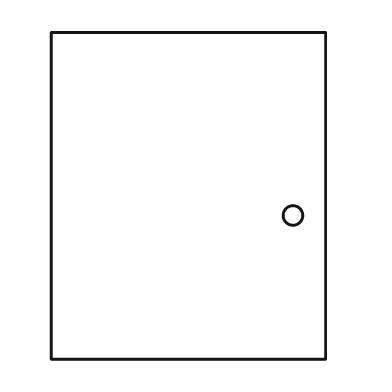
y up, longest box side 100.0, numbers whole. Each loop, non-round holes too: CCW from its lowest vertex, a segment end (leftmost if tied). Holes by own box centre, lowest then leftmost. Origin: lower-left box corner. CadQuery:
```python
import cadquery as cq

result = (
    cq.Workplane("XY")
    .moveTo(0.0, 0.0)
    .lineTo(84.0, 0.0)
    .lineTo(84.0, 100.0)
    .lineTo(0.0, 100.0)
    .close()
    .moveTo(74.0, 44.0)
    .circle(3.0)
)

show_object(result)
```